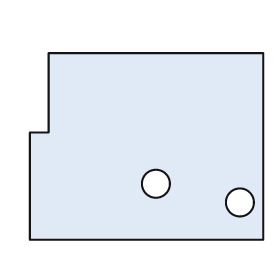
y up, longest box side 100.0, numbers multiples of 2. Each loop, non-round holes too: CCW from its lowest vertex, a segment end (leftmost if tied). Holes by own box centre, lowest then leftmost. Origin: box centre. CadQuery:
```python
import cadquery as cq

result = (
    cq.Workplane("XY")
    .moveTo(-50.0, -40.0)
    .lineTo(50.0, -40.0)
    .lineTo(50.0, 40.0)
    .lineTo(-42.0, 40.0)
    .lineTo(-42.0, 6.0)
    .lineTo(-50.0, 6.0)
    .close()
    .moveTo(40.0, -24.0)
    .circle(6.0)
    .moveTo(4.0, -16.0)
    .circle(6.0)
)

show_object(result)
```